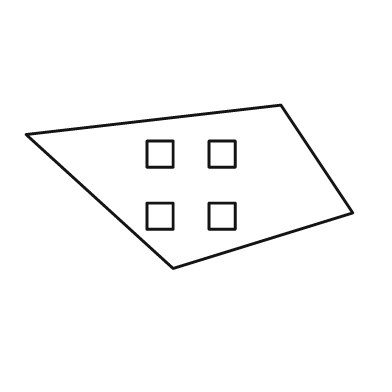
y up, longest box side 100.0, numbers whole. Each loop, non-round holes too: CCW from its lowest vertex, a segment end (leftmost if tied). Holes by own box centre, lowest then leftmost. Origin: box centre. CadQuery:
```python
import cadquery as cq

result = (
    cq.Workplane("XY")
    .moveTo(-5.0, -25.0)
    .lineTo(50.0, -8.0)
    .lineTo(28.0, 25.0)
    .lineTo(-50.0, 16.0)
    .close()
    .moveTo(-13.0, -13.0)
    .lineTo(-5.0, -13.0)
    .lineTo(-5.0, -5.0)
    .lineTo(-13.0, -5.0)
    .close()
    .moveTo(6.0, -13.0)
    .lineTo(14.0, -13.0)
    .lineTo(14.0, -5.0)
    .lineTo(6.0, -5.0)
    .close()
    .moveTo(-13.0, 6.0)
    .lineTo(-5.0, 6.0)
    .lineTo(-5.0, 14.0)
    .lineTo(-13.0, 14.0)
    .close()
    .moveTo(6.0, 6.0)
    .lineTo(14.0, 6.0)
    .lineTo(14.0, 14.0)
    .lineTo(6.0, 14.0)
    .close()
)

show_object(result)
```